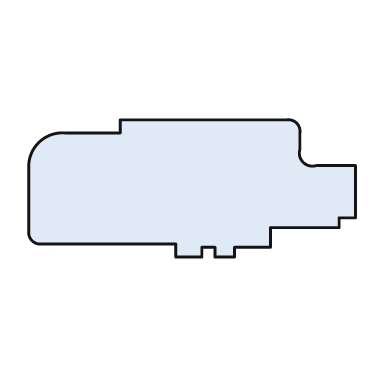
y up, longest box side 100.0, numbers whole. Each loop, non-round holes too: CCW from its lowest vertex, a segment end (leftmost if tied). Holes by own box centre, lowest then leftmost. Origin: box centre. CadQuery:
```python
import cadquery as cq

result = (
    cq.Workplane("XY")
    .moveTo(-5.0, -21.0)
    .lineTo(3.0, -21.0)
    .lineTo(3.0, -18.0)
    .lineTo(7.0, -18.0)
    .lineTo(7.0, -21.0)
    .lineTo(13.0, -21.0)
    .lineTo(13.0, -18.0)
    .lineTo(24.0, -18.0)
    .lineTo(24.0, -12.0)
    .lineTo(45.0, -12.0)
    .lineTo(45.0, -9.0)
    .lineTo(50.0, -9.0)
    .lineTo(50.0, 7.0)
    .lineTo(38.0, 7.0)
    .threePointArc((34.0, 8.0), (33.0, 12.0))
    .lineTo(33.0, 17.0)
    .threePointArc((32.0, 20.0), (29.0, 21.0))
    .lineTo(-22.0, 21.0)
    .lineTo(-22.0, 17.0)
    .lineTo(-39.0, 17.0)
    .threePointArc((-47.0, 14.0), (-50.0, 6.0))
    .lineTo(-50.0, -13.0)
    .threePointArc((-49.0, -16.0), (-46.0, -17.0))
    .lineTo(-5.0, -17.0)
    .close()
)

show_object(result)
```